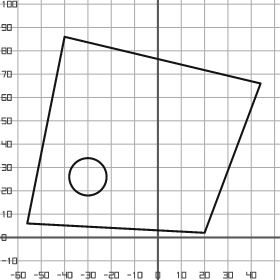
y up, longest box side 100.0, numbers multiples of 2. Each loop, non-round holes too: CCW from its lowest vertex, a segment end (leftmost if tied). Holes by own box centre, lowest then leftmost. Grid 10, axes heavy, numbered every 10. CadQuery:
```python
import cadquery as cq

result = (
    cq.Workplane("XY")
    .moveTo(20.0, 2.0)
    .lineTo(44.0, 66.0)
    .lineTo(-40.0, 86.0)
    .lineTo(-56.0, 6.0)
    .close()
    .moveTo(-30.0, 26.0)
    .circle(8.0)
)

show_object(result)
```